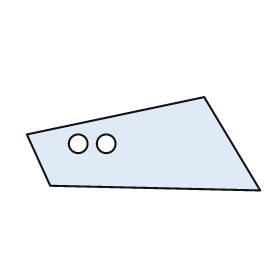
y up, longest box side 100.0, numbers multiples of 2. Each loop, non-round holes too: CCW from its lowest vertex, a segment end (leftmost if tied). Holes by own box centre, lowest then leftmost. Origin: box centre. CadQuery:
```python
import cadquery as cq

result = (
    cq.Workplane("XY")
    .moveTo(50.0, -20.0)
    .lineTo(26.0, 20.0)
    .lineTo(-50.0, 4.0)
    .lineTo(-40.0, -18.0)
    .close()
    .moveTo(-28.0, 0.0)
    .circle(4.0)
    .moveTo(-16.0, 0.0)
    .circle(4.0)
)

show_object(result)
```